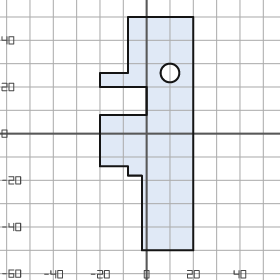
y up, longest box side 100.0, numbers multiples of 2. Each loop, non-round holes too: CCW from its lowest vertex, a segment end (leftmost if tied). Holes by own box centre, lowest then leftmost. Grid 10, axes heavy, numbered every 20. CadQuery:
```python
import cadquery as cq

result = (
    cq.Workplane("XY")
    .moveTo(-2.0, -50.0)
    .lineTo(20.0, -50.0)
    .lineTo(20.0, 50.0)
    .lineTo(-8.0, 50.0)
    .lineTo(-8.0, 26.0)
    .lineTo(-20.0, 26.0)
    .lineTo(-20.0, 20.0)
    .lineTo(0.0, 20.0)
    .lineTo(0.0, 8.0)
    .lineTo(-20.0, 8.0)
    .lineTo(-20.0, -14.0)
    .lineTo(-8.0, -14.0)
    .lineTo(-8.0, -18.0)
    .lineTo(-2.0, -18.0)
    .close()
    .moveTo(10.0, 26.0)
    .circle(4.0)
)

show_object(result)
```